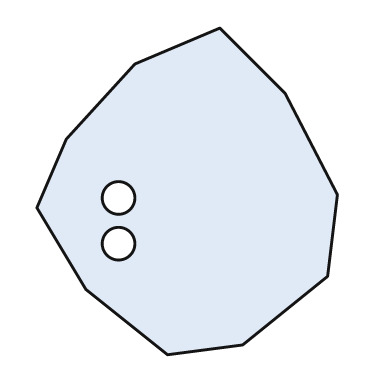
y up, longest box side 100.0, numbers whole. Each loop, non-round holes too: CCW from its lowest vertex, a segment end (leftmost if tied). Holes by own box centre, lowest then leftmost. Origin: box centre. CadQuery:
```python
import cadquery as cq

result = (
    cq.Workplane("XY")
    .moveTo(-6.0, -50.0)
    .lineTo(17.0, -47.0)
    .lineTo(43.0, -26.0)
    .lineTo(46.0, -1.0)
    .lineTo(30.0, 30.0)
    .lineTo(10.0, 50.0)
    .lineTo(-16.0, 39.0)
    .lineTo(-37.0, 16.0)
    .lineTo(-46.0, -5.0)
    .lineTo(-31.0, -30.0)
    .close()
    .moveTo(-21.0, -16.0)
    .circle(5.0)
    .moveTo(-21.0, -2.0)
    .circle(5.0)
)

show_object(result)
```